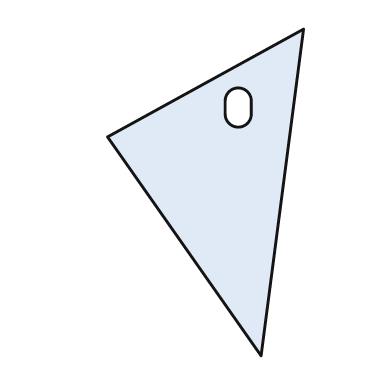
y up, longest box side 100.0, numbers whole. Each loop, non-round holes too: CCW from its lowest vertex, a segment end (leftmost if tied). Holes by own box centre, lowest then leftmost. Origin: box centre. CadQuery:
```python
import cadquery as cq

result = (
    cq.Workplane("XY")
    .moveTo(17.0, -50.0)
    .lineTo(30.0, 50.0)
    .lineTo(-30.0, 17.0)
    .close()
    .moveTo(6.0, 24.0)
    .threePointArc((10.0, 20.0), (14.0, 24.0))
    .lineTo(14.0, 28.0)
    .threePointArc((10.0, 32.0), (6.0, 28.0))
    .close()
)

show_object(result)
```